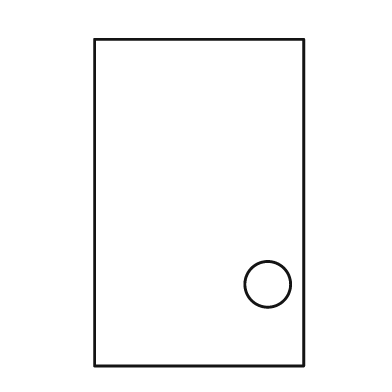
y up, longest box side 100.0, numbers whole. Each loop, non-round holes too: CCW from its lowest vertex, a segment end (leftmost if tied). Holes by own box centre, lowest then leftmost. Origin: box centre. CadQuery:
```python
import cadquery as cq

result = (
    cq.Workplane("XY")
    .moveTo(-32.0, -50.0)
    .lineTo(32.0, -50.0)
    .lineTo(32.0, 50.0)
    .lineTo(-32.0, 50.0)
    .close()
    .moveTo(21.0, -25.0)
    .circle(7.0)
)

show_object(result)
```